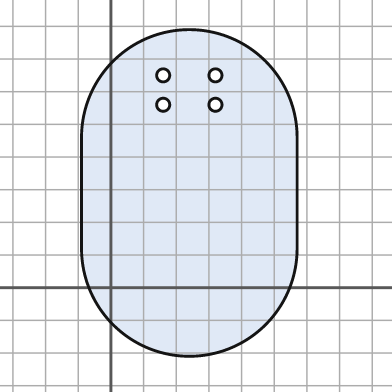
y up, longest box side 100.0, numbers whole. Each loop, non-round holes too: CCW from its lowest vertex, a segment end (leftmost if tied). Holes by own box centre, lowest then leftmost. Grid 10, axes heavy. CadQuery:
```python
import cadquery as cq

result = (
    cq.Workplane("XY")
    .moveTo(-9.0, 12.0)
    .threePointArc((24.0, -21.0), (57.0, 12.0))
    .lineTo(57.0, 46.0)
    .threePointArc((24.0, 79.0), (-9.0, 46.0))
    .close()
    .moveTo(16.0, 56.0)
    .circle(2.0)
    .moveTo(32.0, 56.0)
    .circle(2.0)
    .moveTo(16.0, 65.0)
    .circle(2.0)
    .moveTo(32.0, 65.0)
    .circle(2.0)
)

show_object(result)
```